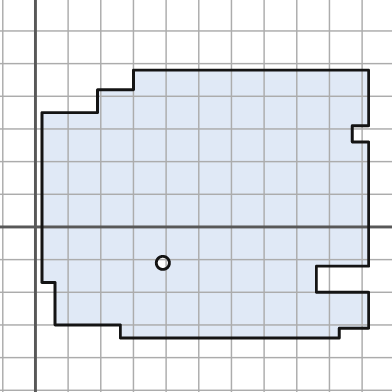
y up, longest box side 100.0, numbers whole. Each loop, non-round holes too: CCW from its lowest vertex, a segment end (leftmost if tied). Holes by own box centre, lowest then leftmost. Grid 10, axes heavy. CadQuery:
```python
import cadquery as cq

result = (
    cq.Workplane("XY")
    .moveTo(26.0, -34.0)
    .lineTo(93.0, -34.0)
    .lineTo(93.0, -31.0)
    .lineTo(102.0, -31.0)
    .lineTo(102.0, -20.0)
    .lineTo(86.0, -20.0)
    .lineTo(86.0, -12.0)
    .lineTo(102.0, -12.0)
    .lineTo(102.0, 26.0)
    .lineTo(97.0, 26.0)
    .lineTo(97.0, 31.0)
    .lineTo(102.0, 31.0)
    .lineTo(102.0, 48.0)
    .lineTo(30.0, 48.0)
    .lineTo(30.0, 42.0)
    .lineTo(19.0, 42.0)
    .lineTo(19.0, 35.0)
    .lineTo(2.0, 35.0)
    .lineTo(2.0, -17.0)
    .lineTo(6.0, -17.0)
    .lineTo(6.0, -30.0)
    .lineTo(26.0, -30.0)
    .close()
    .moveTo(39.0, -11.0)
    .circle(2.0)
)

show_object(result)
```